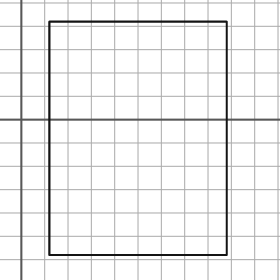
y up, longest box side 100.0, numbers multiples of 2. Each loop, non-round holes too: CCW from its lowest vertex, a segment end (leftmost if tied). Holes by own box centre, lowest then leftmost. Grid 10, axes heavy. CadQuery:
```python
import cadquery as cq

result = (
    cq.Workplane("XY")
    .moveTo(12.0, -58.0)
    .lineTo(88.0, -58.0)
    .lineTo(88.0, 42.0)
    .lineTo(12.0, 42.0)
    .close()
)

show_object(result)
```